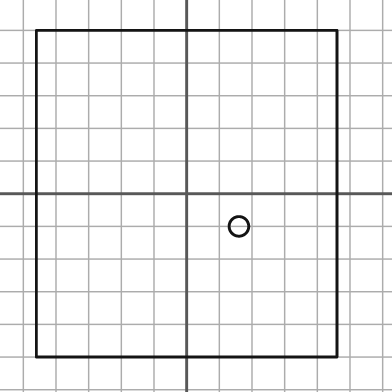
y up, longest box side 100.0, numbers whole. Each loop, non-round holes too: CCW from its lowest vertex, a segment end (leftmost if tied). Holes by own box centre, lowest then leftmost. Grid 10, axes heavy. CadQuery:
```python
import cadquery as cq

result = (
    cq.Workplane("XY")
    .moveTo(-46.0, -50.0)
    .lineTo(46.0, -50.0)
    .lineTo(46.0, 50.0)
    .lineTo(-46.0, 50.0)
    .close()
    .moveTo(16.0, -10.0)
    .circle(3.0)
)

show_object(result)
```